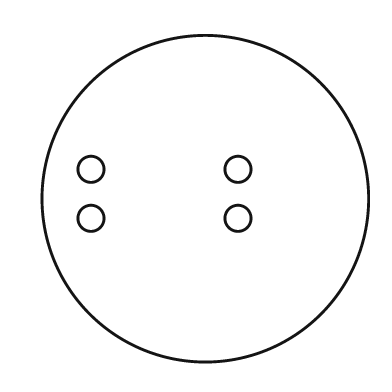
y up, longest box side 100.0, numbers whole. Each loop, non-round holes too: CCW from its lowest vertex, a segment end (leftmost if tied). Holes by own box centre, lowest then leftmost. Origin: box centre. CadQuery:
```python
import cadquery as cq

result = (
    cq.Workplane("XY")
    .moveTo(0.0, 0.0)
    .circle(50.0)
    .moveTo(-35.0, -6.0)
    .circle(4.0)
    .moveTo(10.0, -6.0)
    .circle(4.0)
    .moveTo(-35.0, 9.0)
    .circle(4.0)
    .moveTo(10.0, 9.0)
    .circle(4.0)
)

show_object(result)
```